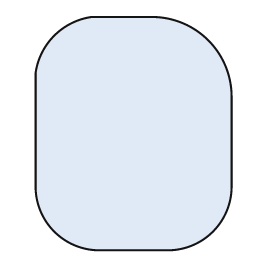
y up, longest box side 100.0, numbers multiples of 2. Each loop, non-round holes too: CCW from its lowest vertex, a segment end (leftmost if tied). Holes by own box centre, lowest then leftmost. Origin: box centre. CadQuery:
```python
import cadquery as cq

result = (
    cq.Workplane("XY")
    .moveTo(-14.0, -50.0)
    .lineTo(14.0, -50.0)
    .threePointArc((34.0, -42.0), (42.0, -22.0))
    .lineTo(42.0, 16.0)
    .threePointArc((32.0, 40.0), (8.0, 50.0))
    .lineTo(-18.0, 50.0)
    .threePointArc((-34.0, 42.0), (-42.0, 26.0))
    .lineTo(-42.0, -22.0)
    .threePointArc((-34.0, -42.0), (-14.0, -50.0))
    .close()
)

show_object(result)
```